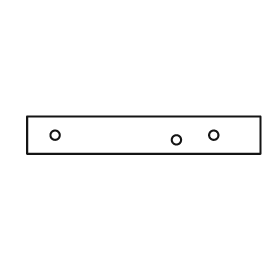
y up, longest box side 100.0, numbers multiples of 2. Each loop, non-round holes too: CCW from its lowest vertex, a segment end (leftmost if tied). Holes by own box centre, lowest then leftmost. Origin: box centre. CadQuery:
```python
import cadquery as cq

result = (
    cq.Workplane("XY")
    .moveTo(-50.0, -8.0)
    .lineTo(50.0, -8.0)
    .lineTo(50.0, 8.0)
    .lineTo(-50.0, 8.0)
    .close()
    .moveTo(14.0, -2.0)
    .circle(2.0)
    .moveTo(-38.0, 0.0)
    .circle(2.0)
    .moveTo(30.0, 0.0)
    .circle(2.0)
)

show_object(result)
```